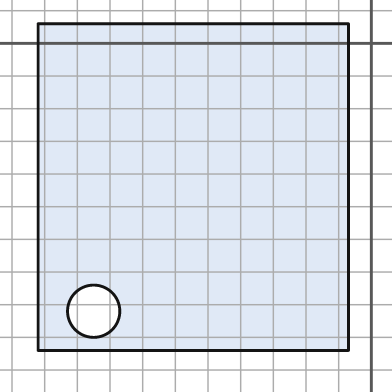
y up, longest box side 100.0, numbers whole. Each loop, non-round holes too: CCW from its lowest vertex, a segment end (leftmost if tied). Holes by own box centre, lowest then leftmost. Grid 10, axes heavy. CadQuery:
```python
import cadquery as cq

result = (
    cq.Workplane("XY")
    .moveTo(-102.0, -94.0)
    .lineTo(-7.0, -94.0)
    .lineTo(-7.0, 6.0)
    .lineTo(-102.0, 6.0)
    .close()
    .moveTo(-85.0, -82.0)
    .circle(8.0)
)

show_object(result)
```